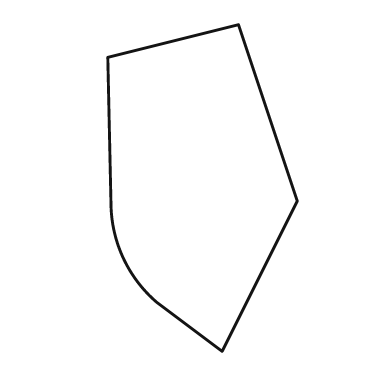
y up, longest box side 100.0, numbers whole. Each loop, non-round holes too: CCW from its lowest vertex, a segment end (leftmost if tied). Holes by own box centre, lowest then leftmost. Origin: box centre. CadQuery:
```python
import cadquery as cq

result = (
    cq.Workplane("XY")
    .moveTo(6.0, -50.0)
    .lineTo(29.0, -4.0)
    .lineTo(11.0, 50.0)
    .lineTo(-29.0, 40.0)
    .lineTo(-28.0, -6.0)
    .threePointArc((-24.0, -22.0), (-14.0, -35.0))
    .close()
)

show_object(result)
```